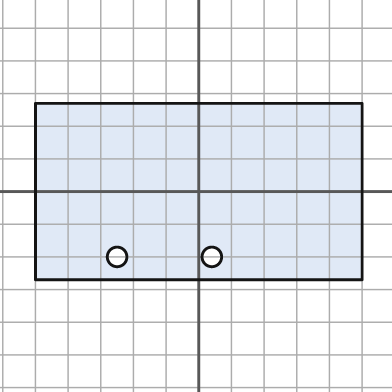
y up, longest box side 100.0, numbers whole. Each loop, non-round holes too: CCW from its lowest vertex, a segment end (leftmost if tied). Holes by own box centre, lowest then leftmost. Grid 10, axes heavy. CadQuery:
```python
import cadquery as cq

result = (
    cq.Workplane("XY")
    .moveTo(-50.0, -27.0)
    .lineTo(50.0, -27.0)
    .lineTo(50.0, 27.0)
    .lineTo(-50.0, 27.0)
    .close()
    .moveTo(-25.0, -20.0)
    .circle(3.0)
    .moveTo(4.0, -20.0)
    .circle(3.0)
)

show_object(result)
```